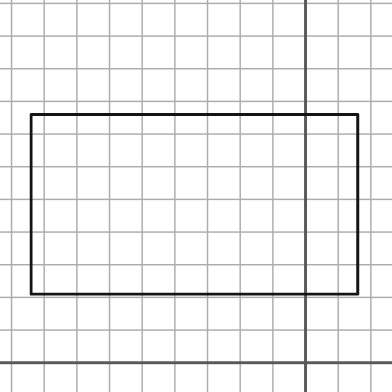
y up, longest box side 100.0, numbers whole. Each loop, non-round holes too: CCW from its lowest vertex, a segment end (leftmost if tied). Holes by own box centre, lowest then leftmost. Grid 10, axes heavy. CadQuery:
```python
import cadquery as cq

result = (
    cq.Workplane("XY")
    .moveTo(-84.0, 21.0)
    .lineTo(16.0, 21.0)
    .lineTo(16.0, 76.0)
    .lineTo(-84.0, 76.0)
    .close()
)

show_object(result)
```